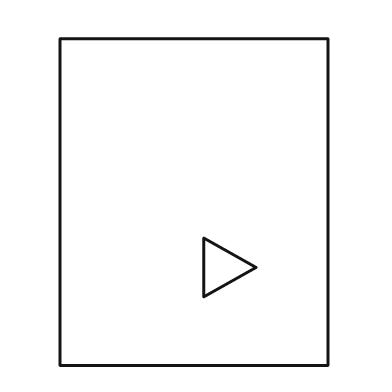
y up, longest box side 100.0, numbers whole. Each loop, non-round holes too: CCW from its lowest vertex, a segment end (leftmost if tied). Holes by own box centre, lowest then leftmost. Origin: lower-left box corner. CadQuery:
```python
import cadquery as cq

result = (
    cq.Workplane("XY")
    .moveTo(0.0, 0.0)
    .lineTo(82.0, 0.0)
    .lineTo(82.0, 100.0)
    .lineTo(0.0, 100.0)
    .close()
    .moveTo(44.0, 21.0)
    .lineTo(60.0, 30.0)
    .lineTo(44.0, 39.0)
    .close()
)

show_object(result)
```